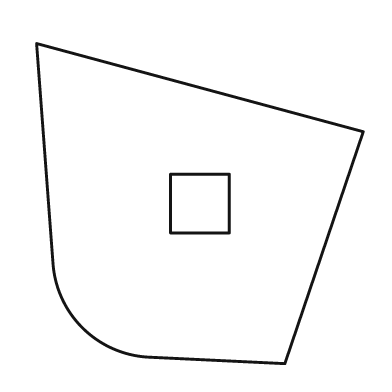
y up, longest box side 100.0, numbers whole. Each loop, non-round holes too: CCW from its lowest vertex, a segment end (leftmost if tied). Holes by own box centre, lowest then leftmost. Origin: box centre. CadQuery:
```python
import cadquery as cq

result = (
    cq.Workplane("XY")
    .moveTo(26.0, -49.0)
    .lineTo(50.0, 22.0)
    .lineTo(-50.0, 49.0)
    .lineTo(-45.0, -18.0)
    .threePointArc((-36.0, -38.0), (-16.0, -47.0))
    .close()
    .moveTo(-9.0, -9.0)
    .lineTo(9.0, -9.0)
    .lineTo(9.0, 9.0)
    .lineTo(-9.0, 9.0)
    .close()
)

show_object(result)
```